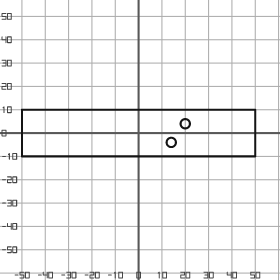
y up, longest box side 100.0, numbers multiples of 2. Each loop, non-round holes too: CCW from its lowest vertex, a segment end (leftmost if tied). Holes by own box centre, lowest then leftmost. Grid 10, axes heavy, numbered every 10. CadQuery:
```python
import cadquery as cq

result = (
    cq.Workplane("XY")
    .moveTo(-50.0, -10.0)
    .lineTo(50.0, -10.0)
    .lineTo(50.0, 10.0)
    .lineTo(-50.0, 10.0)
    .close()
    .moveTo(14.0, -4.0)
    .circle(2.0)
    .moveTo(20.0, 4.0)
    .circle(2.0)
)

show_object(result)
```